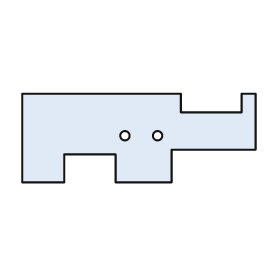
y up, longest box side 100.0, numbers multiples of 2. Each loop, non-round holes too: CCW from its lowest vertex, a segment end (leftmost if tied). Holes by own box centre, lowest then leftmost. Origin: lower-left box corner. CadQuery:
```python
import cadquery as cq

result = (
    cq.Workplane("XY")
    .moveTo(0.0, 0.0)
    .lineTo(18.0, 0.0)
    .lineTo(18.0, 12.0)
    .lineTo(40.0, 12.0)
    .lineTo(40.0, 0.0)
    .lineTo(64.0, 0.0)
    .lineTo(64.0, 14.0)
    .lineTo(100.0, 14.0)
    .lineTo(100.0, 38.0)
    .lineTo(94.0, 38.0)
    .lineTo(94.0, 30.0)
    .lineTo(68.0, 30.0)
    .lineTo(68.0, 38.0)
    .lineTo(0.0, 38.0)
    .close()
    .moveTo(44.0, 20.0)
    .circle(2.0)
    .moveTo(58.0, 20.0)
    .circle(2.0)
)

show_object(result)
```